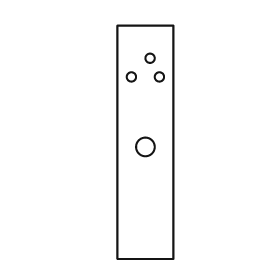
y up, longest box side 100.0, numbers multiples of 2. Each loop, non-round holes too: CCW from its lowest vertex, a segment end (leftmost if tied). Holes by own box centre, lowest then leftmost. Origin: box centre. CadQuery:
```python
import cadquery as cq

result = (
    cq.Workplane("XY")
    .moveTo(-12.0, -50.0)
    .lineTo(12.0, -50.0)
    .lineTo(12.0, 50.0)
    .lineTo(-12.0, 50.0)
    .close()
    .moveTo(0.0, -2.0)
    .circle(4.0)
    .moveTo(-6.0, 28.0)
    .circle(2.0)
    .moveTo(6.0, 28.0)
    .circle(2.0)
    .moveTo(2.0, 36.0)
    .circle(2.0)
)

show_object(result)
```